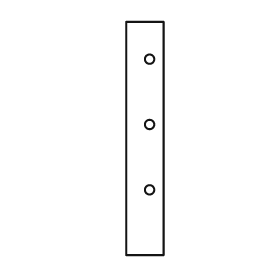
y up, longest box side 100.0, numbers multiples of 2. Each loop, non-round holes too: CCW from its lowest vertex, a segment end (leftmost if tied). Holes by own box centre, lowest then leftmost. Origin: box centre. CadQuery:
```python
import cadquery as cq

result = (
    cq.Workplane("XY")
    .moveTo(-8.0, -50.0)
    .lineTo(8.0, -50.0)
    .lineTo(8.0, 50.0)
    .lineTo(-8.0, 50.0)
    .close()
    .moveTo(2.0, -22.0)
    .circle(2.0)
    .moveTo(2.0, 6.0)
    .circle(2.0)
    .moveTo(2.0, 34.0)
    .circle(2.0)
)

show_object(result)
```